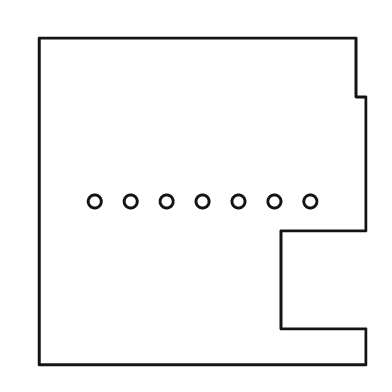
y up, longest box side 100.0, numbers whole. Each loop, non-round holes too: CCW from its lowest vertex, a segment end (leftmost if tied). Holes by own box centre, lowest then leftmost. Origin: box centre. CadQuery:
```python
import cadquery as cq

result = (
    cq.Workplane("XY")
    .moveTo(-50.0, -50.0)
    .lineTo(50.0, -50.0)
    .lineTo(50.0, -39.0)
    .lineTo(24.0, -39.0)
    .lineTo(24.0, -9.0)
    .lineTo(50.0, -9.0)
    .lineTo(50.0, 32.0)
    .lineTo(47.0, 32.0)
    .lineTo(47.0, 50.0)
    .lineTo(-50.0, 50.0)
    .close()
    .moveTo(-33.0, 0.0)
    .circle(2.0)
    .moveTo(-22.0, 0.0)
    .circle(2.0)
    .moveTo(-11.0, 0.0)
    .circle(2.0)
    .moveTo(0.0, 0.0)
    .circle(2.0)
    .moveTo(11.0, 0.0)
    .circle(2.0)
    .moveTo(22.0, 0.0)
    .circle(2.0)
    .moveTo(33.0, 0.0)
    .circle(2.0)
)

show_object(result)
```